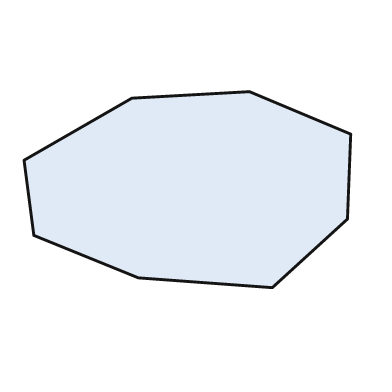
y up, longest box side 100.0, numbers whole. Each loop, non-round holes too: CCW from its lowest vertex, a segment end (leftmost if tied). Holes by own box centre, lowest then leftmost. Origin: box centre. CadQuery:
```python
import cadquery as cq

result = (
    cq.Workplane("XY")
    .moveTo(26.0, -30.0)
    .lineTo(49.0, -9.0)
    .lineTo(50.0, 17.0)
    .lineTo(19.0, 30.0)
    .lineTo(-17.0, 28.0)
    .lineTo(-50.0, 9.0)
    .lineTo(-47.0, -14.0)
    .lineTo(-15.0, -27.0)
    .close()
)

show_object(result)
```